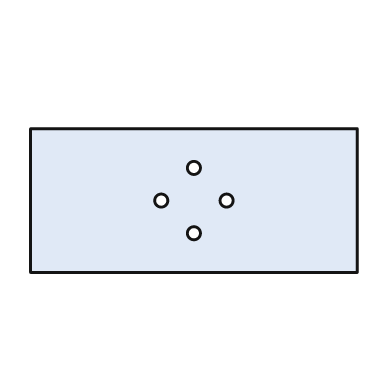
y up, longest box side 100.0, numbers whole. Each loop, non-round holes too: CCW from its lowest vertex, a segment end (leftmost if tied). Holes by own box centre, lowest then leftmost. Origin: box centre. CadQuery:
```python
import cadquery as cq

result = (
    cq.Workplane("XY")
    .moveTo(-50.0, -22.0)
    .lineTo(50.0, -22.0)
    .lineTo(50.0, 22.0)
    .lineTo(-50.0, 22.0)
    .close()
    .moveTo(0.0, -10.0)
    .circle(2.0)
    .moveTo(-10.0, 0.0)
    .circle(2.0)
    .moveTo(10.0, 0.0)
    .circle(2.0)
    .moveTo(0.0, 10.0)
    .circle(2.0)
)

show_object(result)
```